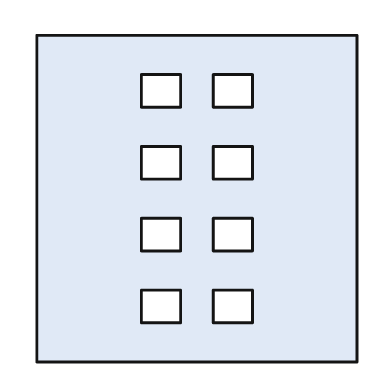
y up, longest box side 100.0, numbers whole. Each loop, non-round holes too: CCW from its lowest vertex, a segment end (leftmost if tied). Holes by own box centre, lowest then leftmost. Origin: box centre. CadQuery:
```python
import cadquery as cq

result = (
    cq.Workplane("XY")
    .moveTo(-49.0, -50.0)
    .lineTo(49.0, -50.0)
    .lineTo(49.0, 50.0)
    .lineTo(-49.0, 50.0)
    .close()
    .moveTo(-17.0, -38.0)
    .lineTo(-5.0, -38.0)
    .lineTo(-5.0, -28.0)
    .lineTo(-17.0, -28.0)
    .close()
    .moveTo(5.0, -38.0)
    .lineTo(17.0, -38.0)
    .lineTo(17.0, -28.0)
    .lineTo(5.0, -28.0)
    .close()
    .moveTo(-17.0, -16.0)
    .lineTo(-5.0, -16.0)
    .lineTo(-5.0, -6.0)
    .lineTo(-17.0, -6.0)
    .close()
    .moveTo(5.0, -16.0)
    .lineTo(17.0, -16.0)
    .lineTo(17.0, -6.0)
    .lineTo(5.0, -6.0)
    .close()
    .moveTo(-17.0, 6.0)
    .lineTo(-5.0, 6.0)
    .lineTo(-5.0, 16.0)
    .lineTo(-17.0, 16.0)
    .close()
    .moveTo(5.0, 6.0)
    .lineTo(17.0, 6.0)
    .lineTo(17.0, 16.0)
    .lineTo(5.0, 16.0)
    .close()
    .moveTo(-17.0, 28.0)
    .lineTo(-5.0, 28.0)
    .lineTo(-5.0, 38.0)
    .lineTo(-17.0, 38.0)
    .close()
    .moveTo(5.0, 28.0)
    .lineTo(17.0, 28.0)
    .lineTo(17.0, 38.0)
    .lineTo(5.0, 38.0)
    .close()
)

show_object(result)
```